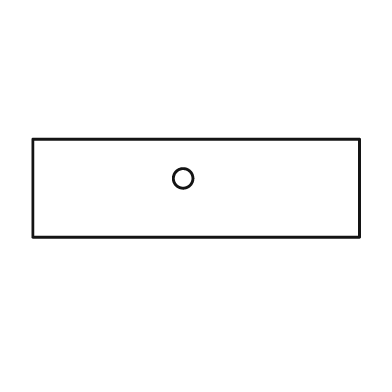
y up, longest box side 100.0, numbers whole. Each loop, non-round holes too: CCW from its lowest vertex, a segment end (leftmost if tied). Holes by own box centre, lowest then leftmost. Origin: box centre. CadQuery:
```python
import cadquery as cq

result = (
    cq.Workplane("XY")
    .moveTo(-50.0, -15.0)
    .lineTo(50.0, -15.0)
    .lineTo(50.0, 15.0)
    .lineTo(-50.0, 15.0)
    .close()
    .moveTo(-4.0, 3.0)
    .circle(3.0)
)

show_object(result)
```